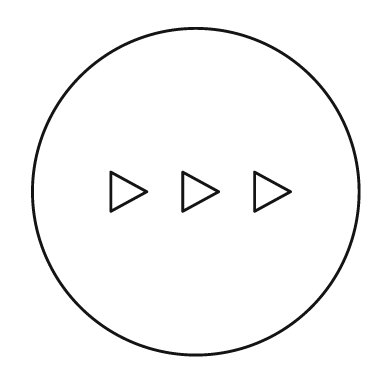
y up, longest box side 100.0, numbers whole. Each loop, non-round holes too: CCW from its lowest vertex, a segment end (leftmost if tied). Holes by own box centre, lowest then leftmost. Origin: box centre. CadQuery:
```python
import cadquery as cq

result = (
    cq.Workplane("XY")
    .moveTo(0.0, 0.0)
    .circle(50.0)
    .moveTo(-26.0, -6.0)
    .lineTo(-15.0, 0.0)
    .lineTo(-26.0, 6.0)
    .close()
    .moveTo(-4.0, -6.0)
    .lineTo(7.0, 0.0)
    .lineTo(-4.0, 6.0)
    .close()
    .moveTo(18.0, -6.0)
    .lineTo(29.0, 0.0)
    .lineTo(18.0, 6.0)
    .close()
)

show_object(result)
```